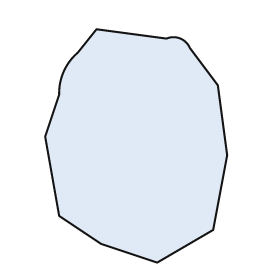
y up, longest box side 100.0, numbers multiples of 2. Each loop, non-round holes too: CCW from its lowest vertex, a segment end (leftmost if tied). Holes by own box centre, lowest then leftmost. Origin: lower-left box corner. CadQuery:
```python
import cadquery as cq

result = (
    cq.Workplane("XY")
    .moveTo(48.0, 0.0)
    .lineTo(72.0, 14.0)
    .lineTo(78.0, 46.0)
    .lineTo(74.0, 76.0)
    .lineTo(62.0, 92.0)
    .threePointArc((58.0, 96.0), (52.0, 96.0))
    .lineTo(22.0, 100.0)
    .lineTo(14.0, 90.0)
    .threePointArc((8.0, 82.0), (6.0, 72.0))
    .lineTo(0.0, 54.0)
    .lineTo(6.0, 20.0)
    .lineTo(24.0, 8.0)
    .close()
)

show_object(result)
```